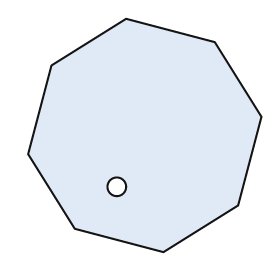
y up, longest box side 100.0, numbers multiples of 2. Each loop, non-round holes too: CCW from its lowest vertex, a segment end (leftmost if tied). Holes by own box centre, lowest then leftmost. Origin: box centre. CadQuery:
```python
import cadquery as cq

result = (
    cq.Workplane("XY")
    .moveTo(8.0, -50.0)
    .lineTo(40.0, -30.0)
    .lineTo(50.0, 8.0)
    .lineTo(30.0, 40.0)
    .lineTo(-8.0, 50.0)
    .lineTo(-40.0, 30.0)
    .lineTo(-50.0, -8.0)
    .lineTo(-30.0, -40.0)
    .close()
    .moveTo(-12.0, -22.0)
    .circle(4.0)
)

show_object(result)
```